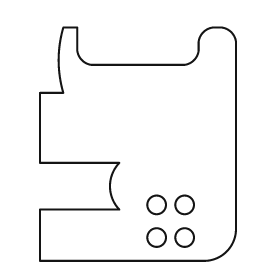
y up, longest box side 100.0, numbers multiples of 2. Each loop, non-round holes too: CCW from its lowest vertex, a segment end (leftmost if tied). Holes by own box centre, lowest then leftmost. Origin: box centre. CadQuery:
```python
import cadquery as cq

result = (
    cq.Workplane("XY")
    .moveTo(-42.0, -50.0)
    .lineTo(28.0, -50.0)
    .threePointArc((38.0, -46.0), (42.0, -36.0))
    .lineTo(42.0, 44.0)
    .threePointArc((40.0, 48.0), (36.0, 50.0))
    .lineTo(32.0, 50.0)
    .threePointArc((28.0, 48.0), (26.0, 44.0))
    .lineTo(26.0, 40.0)
    .threePointArc((24.0, 36.0), (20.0, 34.0))
    .lineTo(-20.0, 34.0)
    .threePointArc((-24.0, 36.0), (-26.0, 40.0))
    .lineTo(-26.0, 50.0)
    .lineTo(-32.0, 50.0)
    .threePointArc((-34.0, 36.0), (-32.0, 22.0))
    .lineTo(-42.0, 22.0)
    .lineTo(-42.0, -8.0)
    .lineTo(-8.0, -8.0)
    .threePointArc((-12.0, -18.0), (-8.0, -28.0))
    .lineTo(-42.0, -28.0)
    .close()
    .moveTo(8.0, -40.0)
    .circle(4.0)
    .moveTo(20.0, -40.0)
    .circle(4.0)
    .moveTo(8.0, -26.0)
    .circle(4.0)
    .moveTo(20.0, -26.0)
    .circle(4.0)
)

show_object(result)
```